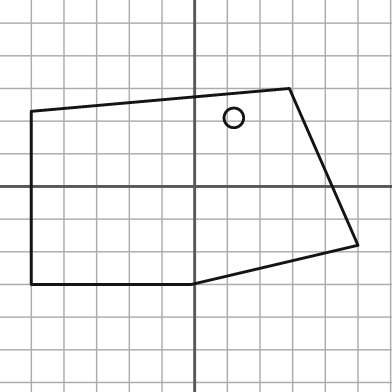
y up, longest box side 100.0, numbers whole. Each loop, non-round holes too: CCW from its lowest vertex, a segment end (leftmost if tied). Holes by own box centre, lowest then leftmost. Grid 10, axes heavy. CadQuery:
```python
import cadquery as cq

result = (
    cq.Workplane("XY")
    .moveTo(-50.0, -30.0)
    .lineTo(-1.0, -30.0)
    .lineTo(50.0, -18.0)
    .lineTo(29.0, 30.0)
    .lineTo(-50.0, 23.0)
    .close()
    .moveTo(12.0, 21.0)
    .circle(3.0)
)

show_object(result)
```